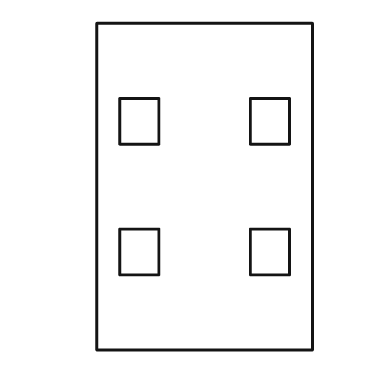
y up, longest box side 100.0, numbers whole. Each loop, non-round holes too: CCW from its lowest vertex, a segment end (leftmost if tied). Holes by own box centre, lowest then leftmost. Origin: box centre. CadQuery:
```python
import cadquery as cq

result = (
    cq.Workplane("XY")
    .moveTo(-33.0, -50.0)
    .lineTo(33.0, -50.0)
    .lineTo(33.0, 50.0)
    .lineTo(-33.0, 50.0)
    .close()
    .moveTo(-26.0, -27.0)
    .lineTo(-14.0, -27.0)
    .lineTo(-14.0, -13.0)
    .lineTo(-26.0, -13.0)
    .close()
    .moveTo(14.0, -27.0)
    .lineTo(26.0, -27.0)
    .lineTo(26.0, -13.0)
    .lineTo(14.0, -13.0)
    .close()
    .moveTo(-26.0, 13.0)
    .lineTo(-14.0, 13.0)
    .lineTo(-14.0, 27.0)
    .lineTo(-26.0, 27.0)
    .close()
    .moveTo(14.0, 13.0)
    .lineTo(26.0, 13.0)
    .lineTo(26.0, 27.0)
    .lineTo(14.0, 27.0)
    .close()
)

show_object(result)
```